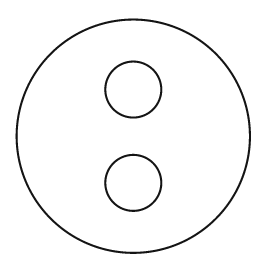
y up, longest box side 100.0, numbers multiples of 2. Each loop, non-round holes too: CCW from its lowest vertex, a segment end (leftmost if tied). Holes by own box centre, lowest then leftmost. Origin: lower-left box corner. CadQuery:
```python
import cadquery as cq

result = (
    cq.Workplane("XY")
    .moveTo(50.0, 50.0)
    .circle(50.0)
    .moveTo(50.0, 30.0)
    .circle(12.0)
    .moveTo(50.0, 70.0)
    .circle(12.0)
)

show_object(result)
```